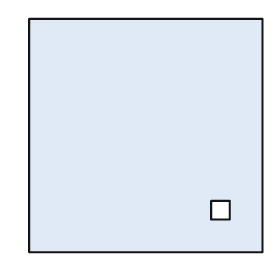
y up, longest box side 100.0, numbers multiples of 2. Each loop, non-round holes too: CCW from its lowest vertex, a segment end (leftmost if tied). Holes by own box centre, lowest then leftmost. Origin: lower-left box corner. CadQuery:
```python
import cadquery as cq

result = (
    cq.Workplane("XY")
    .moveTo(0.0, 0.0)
    .lineTo(100.0, 0.0)
    .lineTo(100.0, 100.0)
    .lineTo(0.0, 100.0)
    .close()
    .moveTo(78.0, 14.0)
    .lineTo(86.0, 14.0)
    .lineTo(86.0, 22.0)
    .lineTo(78.0, 22.0)
    .close()
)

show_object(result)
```